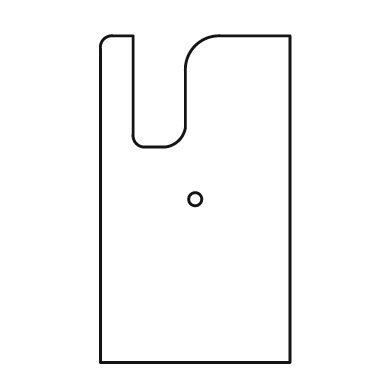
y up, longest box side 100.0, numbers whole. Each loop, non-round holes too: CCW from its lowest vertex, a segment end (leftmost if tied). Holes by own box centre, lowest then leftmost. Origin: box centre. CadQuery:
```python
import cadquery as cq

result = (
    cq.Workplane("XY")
    .moveTo(-29.0, -50.0)
    .lineTo(29.0, -50.0)
    .lineTo(29.0, 50.0)
    .lineTo(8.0, 50.0)
    .threePointArc((0.0, 47.0), (-3.0, 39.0))
    .lineTo(-3.0, 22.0)
    .threePointArc((-5.0, 18.0), (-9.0, 16.0))
    .lineTo(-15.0, 16.0)
    .threePointArc((-18.0, 17.0), (-19.0, 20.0))
    .lineTo(-19.0, 50.0)
    .lineTo(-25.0, 50.0)
    .threePointArc((-28.0, 49.0), (-29.0, 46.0))
    .close()
    .moveTo(0.0, 0.0)
    .circle(2.0)
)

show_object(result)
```